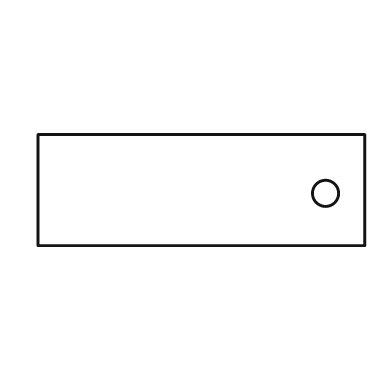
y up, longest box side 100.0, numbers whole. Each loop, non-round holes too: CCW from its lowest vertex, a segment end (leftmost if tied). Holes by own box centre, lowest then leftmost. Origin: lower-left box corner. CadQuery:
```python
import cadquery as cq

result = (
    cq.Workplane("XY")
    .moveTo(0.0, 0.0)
    .lineTo(100.0, 0.0)
    .lineTo(100.0, 34.0)
    .lineTo(0.0, 34.0)
    .close()
    .moveTo(88.0, 16.0)
    .circle(4.0)
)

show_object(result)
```